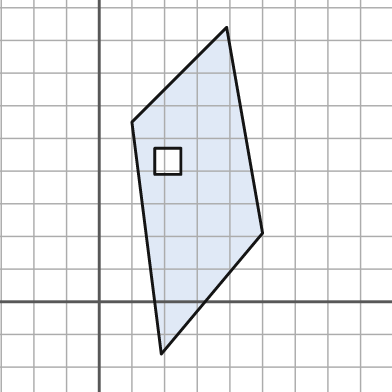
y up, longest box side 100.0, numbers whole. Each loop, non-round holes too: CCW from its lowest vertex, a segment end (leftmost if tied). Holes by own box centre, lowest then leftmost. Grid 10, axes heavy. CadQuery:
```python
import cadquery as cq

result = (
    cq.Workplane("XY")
    .moveTo(19.0, -16.0)
    .lineTo(50.0, 21.0)
    .lineTo(39.0, 84.0)
    .lineTo(10.0, 55.0)
    .close()
    .moveTo(17.0, 39.0)
    .lineTo(25.0, 39.0)
    .lineTo(25.0, 47.0)
    .lineTo(17.0, 47.0)
    .close()
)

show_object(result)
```